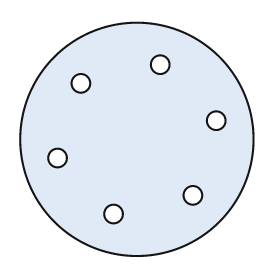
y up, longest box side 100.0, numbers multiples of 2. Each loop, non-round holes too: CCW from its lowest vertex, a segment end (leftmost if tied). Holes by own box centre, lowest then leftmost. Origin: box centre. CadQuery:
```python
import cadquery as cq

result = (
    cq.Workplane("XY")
    .moveTo(0.0, 0.0)
    .circle(50.0)
    .moveTo(-10.0, -32.0)
    .circle(4.0)
    .moveTo(24.0, -24.0)
    .circle(4.0)
    .moveTo(-34.0, -8.0)
    .circle(4.0)
    .moveTo(34.0, 8.0)
    .circle(4.0)
    .moveTo(-24.0, 24.0)
    .circle(4.0)
    .moveTo(10.0, 32.0)
    .circle(4.0)
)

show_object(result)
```